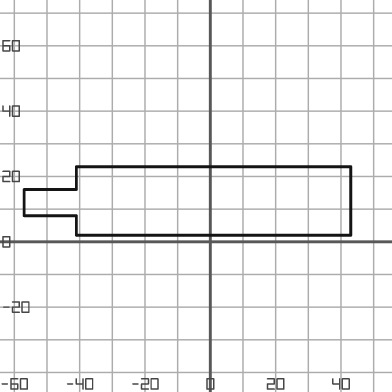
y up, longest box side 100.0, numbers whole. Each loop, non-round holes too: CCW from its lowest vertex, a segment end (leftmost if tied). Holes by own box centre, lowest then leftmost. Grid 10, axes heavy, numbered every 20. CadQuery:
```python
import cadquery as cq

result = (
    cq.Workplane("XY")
    .moveTo(-41.0, 2.0)
    .lineTo(43.0, 2.0)
    .lineTo(43.0, 23.0)
    .lineTo(-41.0, 23.0)
    .lineTo(-41.0, 16.0)
    .lineTo(-57.0, 16.0)
    .lineTo(-57.0, 8.0)
    .lineTo(-41.0, 8.0)
    .close()
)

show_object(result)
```